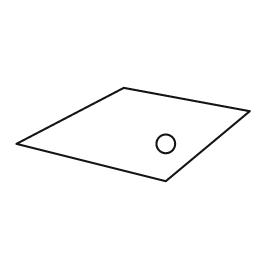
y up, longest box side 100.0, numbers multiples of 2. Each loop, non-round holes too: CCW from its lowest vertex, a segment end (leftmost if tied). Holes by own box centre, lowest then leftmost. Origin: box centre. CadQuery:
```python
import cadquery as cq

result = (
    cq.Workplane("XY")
    .moveTo(14.0, -20.0)
    .lineTo(50.0, 10.0)
    .lineTo(-4.0, 20.0)
    .lineTo(-50.0, -4.0)
    .close()
    .moveTo(14.0, -4.0)
    .circle(4.0)
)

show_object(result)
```